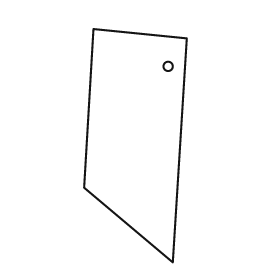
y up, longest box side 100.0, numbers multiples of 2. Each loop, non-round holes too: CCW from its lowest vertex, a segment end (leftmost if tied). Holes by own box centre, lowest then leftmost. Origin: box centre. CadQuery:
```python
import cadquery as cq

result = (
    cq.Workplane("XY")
    .moveTo(16.0, -50.0)
    .lineTo(22.0, 46.0)
    .lineTo(-18.0, 50.0)
    .lineTo(-22.0, -18.0)
    .close()
    .moveTo(14.0, 34.0)
    .circle(2.0)
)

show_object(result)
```